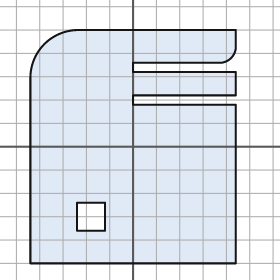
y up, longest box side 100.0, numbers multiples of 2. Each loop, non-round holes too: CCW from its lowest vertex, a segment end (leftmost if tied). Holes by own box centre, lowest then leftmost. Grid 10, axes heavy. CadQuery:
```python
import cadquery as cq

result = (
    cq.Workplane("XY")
    .moveTo(-44.0, -50.0)
    .lineTo(44.0, -50.0)
    .lineTo(44.0, 18.0)
    .lineTo(0.0, 18.0)
    .lineTo(0.0, 22.0)
    .lineTo(44.0, 22.0)
    .lineTo(44.0, 32.0)
    .lineTo(0.0, 32.0)
    .lineTo(0.0, 36.0)
    .lineTo(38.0, 36.0)
    .threePointArc((42.0, 38.0), (44.0, 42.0))
    .lineTo(44.0, 50.0)
    .lineTo(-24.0, 50.0)
    .threePointArc((-38.0, 44.0), (-44.0, 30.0))
    .close()
    .moveTo(-24.0, -36.0)
    .lineTo(-12.0, -36.0)
    .lineTo(-12.0, -24.0)
    .lineTo(-24.0, -24.0)
    .close()
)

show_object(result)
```